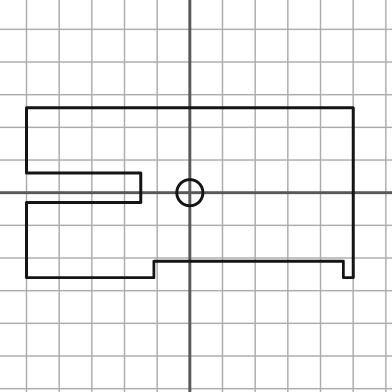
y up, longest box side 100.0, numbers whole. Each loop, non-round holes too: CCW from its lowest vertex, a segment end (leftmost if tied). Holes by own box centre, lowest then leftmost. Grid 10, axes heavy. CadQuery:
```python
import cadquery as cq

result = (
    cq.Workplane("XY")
    .moveTo(-50.0, -26.0)
    .lineTo(-11.0, -26.0)
    .lineTo(-11.0, -21.0)
    .lineTo(47.0, -21.0)
    .lineTo(47.0, -26.0)
    .lineTo(50.0, -26.0)
    .lineTo(50.0, 26.0)
    .lineTo(-50.0, 26.0)
    .lineTo(-50.0, 6.0)
    .lineTo(-15.0, 6.0)
    .lineTo(-15.0, -3.0)
    .lineTo(-50.0, -3.0)
    .close()
    .moveTo(0.0, 0.0)
    .circle(4.0)
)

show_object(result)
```